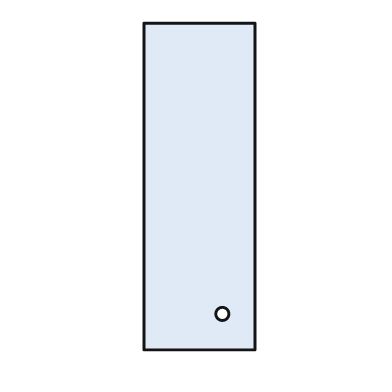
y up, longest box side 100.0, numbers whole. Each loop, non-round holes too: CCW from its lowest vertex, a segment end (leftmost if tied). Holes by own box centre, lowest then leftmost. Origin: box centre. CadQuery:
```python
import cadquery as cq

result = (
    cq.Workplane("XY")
    .moveTo(-17.0, -50.0)
    .lineTo(17.0, -50.0)
    .lineTo(17.0, 50.0)
    .lineTo(-17.0, 50.0)
    .close()
    .moveTo(7.0, -39.0)
    .circle(2.0)
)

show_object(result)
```